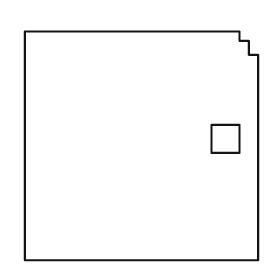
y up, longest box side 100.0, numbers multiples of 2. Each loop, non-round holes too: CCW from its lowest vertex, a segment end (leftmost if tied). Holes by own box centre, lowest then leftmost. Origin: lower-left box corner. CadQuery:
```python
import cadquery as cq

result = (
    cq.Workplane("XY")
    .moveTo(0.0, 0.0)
    .lineTo(100.0, 0.0)
    .lineTo(100.0, 88.0)
    .lineTo(96.0, 88.0)
    .lineTo(96.0, 94.0)
    .lineTo(92.0, 94.0)
    .lineTo(92.0, 98.0)
    .lineTo(0.0, 98.0)
    .close()
    .moveTo(80.0, 46.0)
    .lineTo(92.0, 46.0)
    .lineTo(92.0, 58.0)
    .lineTo(80.0, 58.0)
    .close()
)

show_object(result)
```